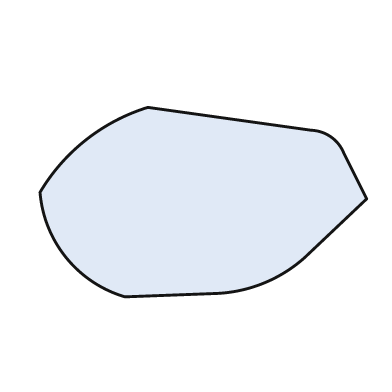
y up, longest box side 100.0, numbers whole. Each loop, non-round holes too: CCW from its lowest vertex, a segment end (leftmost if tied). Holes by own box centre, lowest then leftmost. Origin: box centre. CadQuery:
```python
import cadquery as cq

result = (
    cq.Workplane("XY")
    .moveTo(-24.0, -29.0)
    .lineTo(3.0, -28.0)
    .threePointArc((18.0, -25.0), (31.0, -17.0))
    .lineTo(50.0, 1.0)
    .lineTo(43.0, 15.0)
    .threePointArc((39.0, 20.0), (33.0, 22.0))
    .lineTo(-17.0, 29.0)
    .threePointArc((-36.0, 19.0), (-50.0, 3.0))
    .threePointArc((-42.0, -17.0), (-24.0, -29.0))
    .close()
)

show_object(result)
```